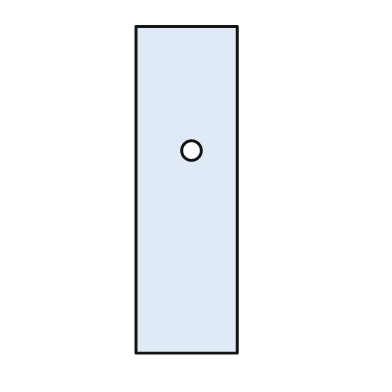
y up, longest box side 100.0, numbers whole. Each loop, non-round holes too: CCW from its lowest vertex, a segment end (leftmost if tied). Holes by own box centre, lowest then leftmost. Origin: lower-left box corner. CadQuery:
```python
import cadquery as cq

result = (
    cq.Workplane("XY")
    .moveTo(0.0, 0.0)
    .lineTo(31.0, 0.0)
    .lineTo(31.0, 100.0)
    .lineTo(0.0, 100.0)
    .close()
    .moveTo(17.0, 62.0)
    .circle(3.0)
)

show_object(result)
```